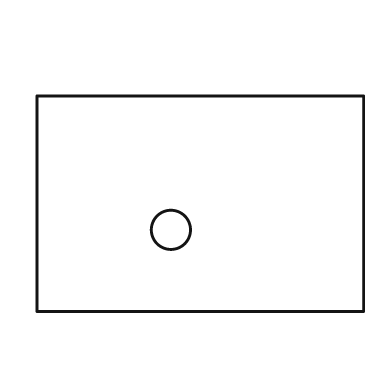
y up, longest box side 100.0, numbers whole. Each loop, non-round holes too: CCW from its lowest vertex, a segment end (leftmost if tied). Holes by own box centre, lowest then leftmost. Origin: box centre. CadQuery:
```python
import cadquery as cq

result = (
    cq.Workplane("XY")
    .moveTo(-50.0, -33.0)
    .lineTo(50.0, -33.0)
    .lineTo(50.0, 33.0)
    .lineTo(-50.0, 33.0)
    .close()
    .moveTo(-9.0, -8.0)
    .circle(6.0)
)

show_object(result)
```